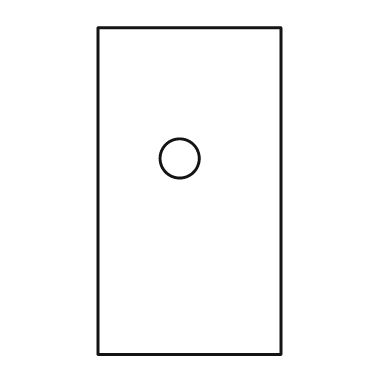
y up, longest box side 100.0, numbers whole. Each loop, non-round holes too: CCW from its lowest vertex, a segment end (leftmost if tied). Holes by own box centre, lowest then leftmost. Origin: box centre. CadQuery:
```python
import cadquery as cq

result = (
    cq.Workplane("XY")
    .moveTo(-28.0, -50.0)
    .lineTo(28.0, -50.0)
    .lineTo(28.0, 50.0)
    .lineTo(-28.0, 50.0)
    .close()
    .moveTo(-3.0, 10.0)
    .circle(6.0)
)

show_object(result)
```